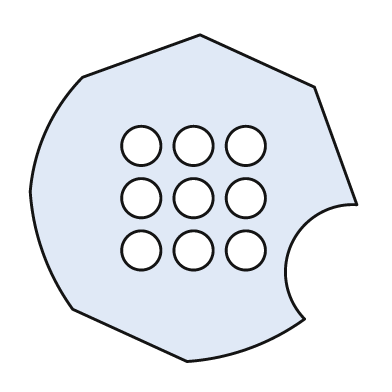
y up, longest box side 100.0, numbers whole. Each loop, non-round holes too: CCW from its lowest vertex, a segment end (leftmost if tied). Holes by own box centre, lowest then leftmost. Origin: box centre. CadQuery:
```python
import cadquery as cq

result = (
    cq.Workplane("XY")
    .moveTo(-2.0, -50.0)
    .threePointArc((17.0, -46.0), (34.0, -37.0))
    .threePointArc((30.0, -14.0), (50.0, -2.0))
    .lineTo(37.0, 34.0)
    .lineTo(2.0, 50.0)
    .lineTo(-34.0, 37.0)
    .threePointArc((-45.0, 21.0), (-50.0, 2.0))
    .threePointArc((-46.0, -17.0), (-37.0, -34.0))
    .close()
    .moveTo(-16.0, -16.0)
    .circle(6.0)
    .moveTo(0.0, -16.0)
    .circle(6.0)
    .moveTo(16.0, -16.0)
    .circle(6.0)
    .moveTo(-16.0, 0.0)
    .circle(6.0)
    .moveTo(0.0, 0.0)
    .circle(6.0)
    .moveTo(16.0, 0.0)
    .circle(6.0)
    .moveTo(-16.0, 16.0)
    .circle(6.0)
    .moveTo(0.0, 16.0)
    .circle(6.0)
    .moveTo(16.0, 16.0)
    .circle(6.0)
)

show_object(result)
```